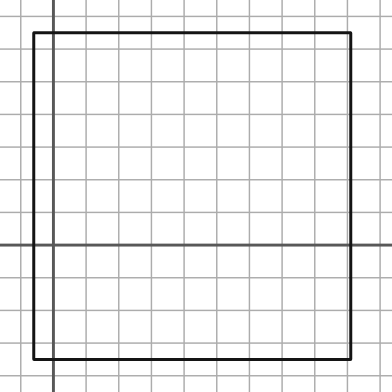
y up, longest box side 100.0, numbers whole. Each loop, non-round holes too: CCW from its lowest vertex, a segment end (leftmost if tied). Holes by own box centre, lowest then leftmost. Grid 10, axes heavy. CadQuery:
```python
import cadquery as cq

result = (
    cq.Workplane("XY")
    .moveTo(-6.0, -35.0)
    .lineTo(91.0, -35.0)
    .lineTo(91.0, 65.0)
    .lineTo(-6.0, 65.0)
    .close()
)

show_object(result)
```